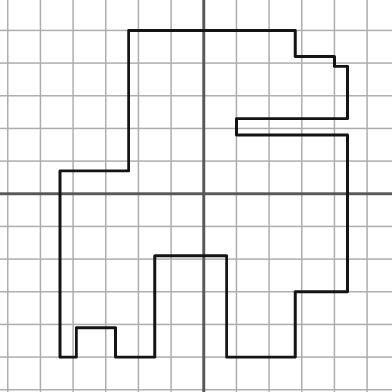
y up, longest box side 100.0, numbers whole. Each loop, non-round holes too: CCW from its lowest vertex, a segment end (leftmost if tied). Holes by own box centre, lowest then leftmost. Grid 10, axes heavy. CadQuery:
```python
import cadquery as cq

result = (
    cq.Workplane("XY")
    .moveTo(-44.0, -50.0)
    .lineTo(-39.0, -50.0)
    .lineTo(-39.0, -41.0)
    .lineTo(-27.0, -41.0)
    .lineTo(-27.0, -50.0)
    .lineTo(-15.0, -50.0)
    .lineTo(-15.0, -19.0)
    .lineTo(7.0, -19.0)
    .lineTo(7.0, -50.0)
    .lineTo(28.0, -50.0)
    .lineTo(28.0, -30.0)
    .lineTo(44.0, -30.0)
    .lineTo(44.0, 18.0)
    .lineTo(10.0, 18.0)
    .lineTo(10.0, 23.0)
    .lineTo(44.0, 23.0)
    .lineTo(44.0, 39.0)
    .lineTo(40.0, 39.0)
    .lineTo(40.0, 42.0)
    .lineTo(28.0, 42.0)
    .lineTo(28.0, 50.0)
    .lineTo(-23.0, 50.0)
    .lineTo(-23.0, 7.0)
    .lineTo(-44.0, 7.0)
    .close()
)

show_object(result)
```